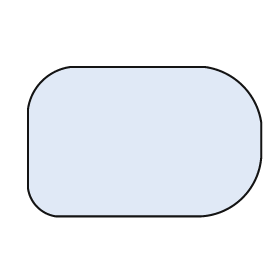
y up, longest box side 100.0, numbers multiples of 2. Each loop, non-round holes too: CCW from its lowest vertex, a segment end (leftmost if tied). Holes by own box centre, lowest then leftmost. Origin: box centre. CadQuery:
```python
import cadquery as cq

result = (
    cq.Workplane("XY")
    .moveTo(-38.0, -32.0)
    .lineTo(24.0, -32.0)
    .threePointArc((42.0, -24.0), (50.0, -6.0))
    .lineTo(50.0, 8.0)
    .threePointArc((42.0, 24.0), (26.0, 32.0))
    .lineTo(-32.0, 32.0)
    .threePointArc((-44.0, 26.0), (-50.0, 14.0))
    .lineTo(-50.0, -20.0)
    .threePointArc((-46.0, -28.0), (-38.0, -32.0))
    .close()
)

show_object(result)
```